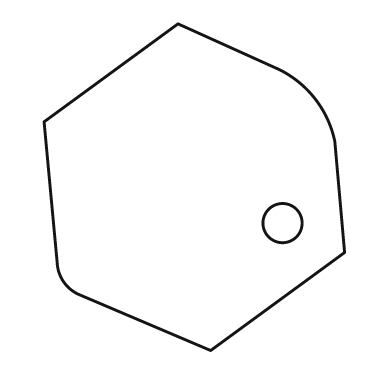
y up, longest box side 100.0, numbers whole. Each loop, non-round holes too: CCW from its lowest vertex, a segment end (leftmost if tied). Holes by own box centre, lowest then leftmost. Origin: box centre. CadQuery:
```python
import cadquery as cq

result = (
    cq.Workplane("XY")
    .moveTo(5.0, -50.0)
    .lineTo(46.0, -20.0)
    .lineTo(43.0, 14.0)
    .threePointArc((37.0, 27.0), (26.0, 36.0))
    .lineTo(-5.0, 50.0)
    .lineTo(-46.0, 20.0)
    .lineTo(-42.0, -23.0)
    .threePointArc((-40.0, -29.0), (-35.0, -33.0))
    .close()
    .moveTo(27.0, -11.0)
    .circle(6.0)
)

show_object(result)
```